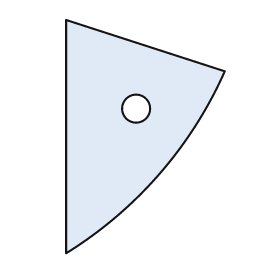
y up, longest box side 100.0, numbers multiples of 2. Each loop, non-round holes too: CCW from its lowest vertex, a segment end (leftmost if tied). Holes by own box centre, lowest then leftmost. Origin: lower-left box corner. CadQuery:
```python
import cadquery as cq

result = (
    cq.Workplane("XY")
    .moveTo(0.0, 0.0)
    .threePointArc((40.0, 34.0), (68.0, 78.0))
    .lineTo(0.0, 100.0)
    .close()
    .moveTo(30.0, 62.0)
    .circle(6.0)
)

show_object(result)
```